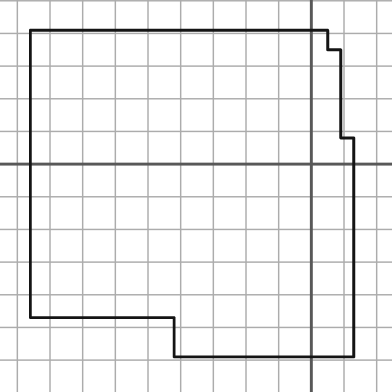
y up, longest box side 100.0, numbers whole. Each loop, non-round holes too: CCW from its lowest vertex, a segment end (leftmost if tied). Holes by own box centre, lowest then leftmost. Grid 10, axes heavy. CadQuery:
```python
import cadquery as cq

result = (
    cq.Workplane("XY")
    .moveTo(-42.0, -59.0)
    .lineTo(13.0, -59.0)
    .lineTo(13.0, 8.0)
    .lineTo(9.0, 8.0)
    .lineTo(9.0, 35.0)
    .lineTo(5.0, 35.0)
    .lineTo(5.0, 41.0)
    .lineTo(-86.0, 41.0)
    .lineTo(-86.0, -47.0)
    .lineTo(-42.0, -47.0)
    .close()
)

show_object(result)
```